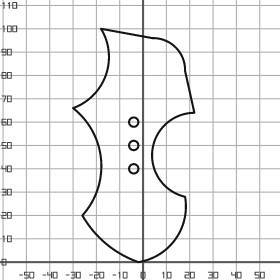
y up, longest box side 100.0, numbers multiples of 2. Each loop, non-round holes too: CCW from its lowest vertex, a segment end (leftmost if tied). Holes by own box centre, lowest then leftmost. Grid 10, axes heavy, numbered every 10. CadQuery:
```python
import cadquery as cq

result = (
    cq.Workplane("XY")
    .moveTo(-2.0, 0.0)
    .threePointArc((14.0, 10.0), (18.0, 28.0))
    .threePointArc((4.0, 48.0), (22.0, 64.0))
    .lineTo(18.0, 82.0)
    .threePointArc((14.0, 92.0), (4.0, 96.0))
    .lineTo(-18.0, 100.0)
    .threePointArc((-16.0, 80.0), (-30.0, 66.0))
    .threePointArc((-18.0, 44.0), (-26.0, 20.0))
    .threePointArc((-16.0, 8.0), (-2.0, 0.0))
    .close()
    .moveTo(-4.0, 40.0)
    .circle(2.0)
    .moveTo(-4.0, 50.0)
    .circle(2.0)
    .moveTo(-4.0, 60.0)
    .circle(2.0)
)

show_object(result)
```